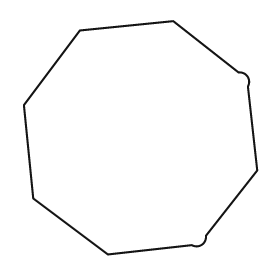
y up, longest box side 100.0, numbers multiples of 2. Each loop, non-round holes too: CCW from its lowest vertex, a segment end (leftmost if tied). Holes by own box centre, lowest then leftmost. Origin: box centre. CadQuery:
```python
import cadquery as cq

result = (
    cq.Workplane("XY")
    .moveTo(-14.0, -50.0)
    .lineTo(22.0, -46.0)
    .threePointArc((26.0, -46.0), (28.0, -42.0))
    .lineTo(50.0, -14.0)
    .lineTo(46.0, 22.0)
    .threePointArc((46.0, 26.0), (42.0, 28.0))
    .lineTo(14.0, 50.0)
    .lineTo(-26.0, 46.0)
    .lineTo(-50.0, 14.0)
    .lineTo(-46.0, -26.0)
    .close()
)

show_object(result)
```